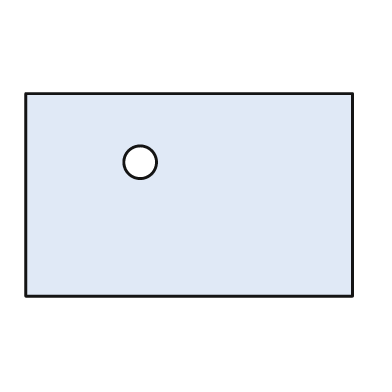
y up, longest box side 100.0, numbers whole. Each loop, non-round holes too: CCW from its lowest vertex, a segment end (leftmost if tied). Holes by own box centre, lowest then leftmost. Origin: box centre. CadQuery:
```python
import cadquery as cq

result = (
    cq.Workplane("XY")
    .moveTo(-50.0, -31.0)
    .lineTo(50.0, -31.0)
    .lineTo(50.0, 31.0)
    .lineTo(-50.0, 31.0)
    .close()
    .moveTo(-15.0, 10.0)
    .circle(5.0)
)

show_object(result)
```